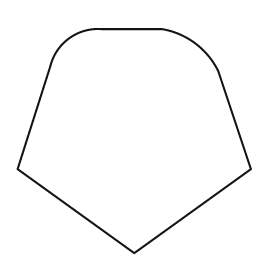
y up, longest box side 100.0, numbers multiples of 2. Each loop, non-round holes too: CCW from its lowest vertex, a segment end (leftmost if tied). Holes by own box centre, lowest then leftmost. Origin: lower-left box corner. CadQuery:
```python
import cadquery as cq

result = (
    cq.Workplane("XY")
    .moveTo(50.0, 0.0)
    .lineTo(100.0, 36.0)
    .lineTo(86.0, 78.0)
    .threePointArc((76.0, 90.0), (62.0, 96.0))
    .lineTo(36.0, 96.0)
    .threePointArc((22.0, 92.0), (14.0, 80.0))
    .lineTo(0.0, 36.0)
    .close()
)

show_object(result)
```